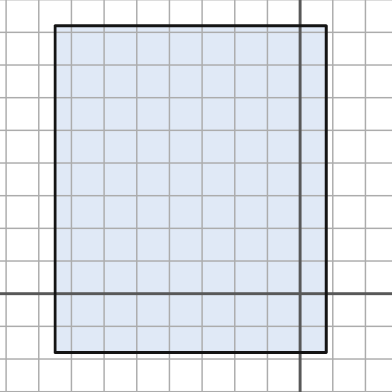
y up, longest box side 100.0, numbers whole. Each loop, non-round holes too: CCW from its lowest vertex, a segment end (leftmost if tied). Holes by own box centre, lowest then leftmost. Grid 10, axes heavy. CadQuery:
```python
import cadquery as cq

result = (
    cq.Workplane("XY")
    .moveTo(-75.0, -18.0)
    .lineTo(8.0, -18.0)
    .lineTo(8.0, 82.0)
    .lineTo(-75.0, 82.0)
    .close()
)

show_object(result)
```